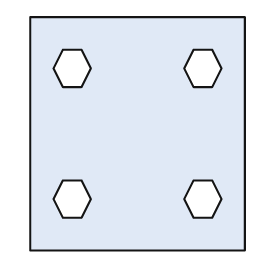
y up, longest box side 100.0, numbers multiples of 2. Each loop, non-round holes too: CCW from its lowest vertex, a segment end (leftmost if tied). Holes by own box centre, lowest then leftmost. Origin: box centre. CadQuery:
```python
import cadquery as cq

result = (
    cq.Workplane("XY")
    .moveTo(-46.0, -50.0)
    .lineTo(46.0, -50.0)
    .lineTo(46.0, 50.0)
    .lineTo(-46.0, 50.0)
    .close()
    .moveTo(-32.0, -36.0)
    .lineTo(-24.0, -36.0)
    .lineTo(-20.0, -28.0)
    .lineTo(-24.0, -20.0)
    .lineTo(-32.0, -20.0)
    .lineTo(-36.0, -28.0)
    .close()
    .moveTo(24.0, -36.0)
    .lineTo(32.0, -36.0)
    .lineTo(36.0, -28.0)
    .lineTo(32.0, -20.0)
    .lineTo(24.0, -20.0)
    .lineTo(20.0, -28.0)
    .close()
    .moveTo(-32.0, 20.0)
    .lineTo(-24.0, 20.0)
    .lineTo(-20.0, 28.0)
    .lineTo(-24.0, 36.0)
    .lineTo(-32.0, 36.0)
    .lineTo(-36.0, 28.0)
    .close()
    .moveTo(24.0, 20.0)
    .lineTo(32.0, 20.0)
    .lineTo(36.0, 28.0)
    .lineTo(32.0, 36.0)
    .lineTo(24.0, 36.0)
    .lineTo(20.0, 28.0)
    .close()
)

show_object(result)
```